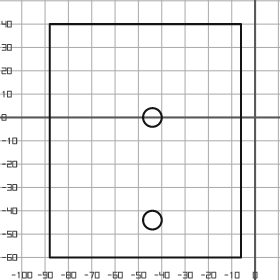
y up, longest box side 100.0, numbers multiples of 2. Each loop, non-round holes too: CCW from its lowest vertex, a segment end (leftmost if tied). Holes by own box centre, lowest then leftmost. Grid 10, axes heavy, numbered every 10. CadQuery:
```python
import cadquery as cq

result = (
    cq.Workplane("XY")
    .moveTo(-88.0, -60.0)
    .lineTo(-6.0, -60.0)
    .lineTo(-6.0, 40.0)
    .lineTo(-88.0, 40.0)
    .close()
    .moveTo(-44.0, -44.0)
    .circle(4.0)
    .moveTo(-44.0, 0.0)
    .circle(4.0)
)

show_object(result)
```